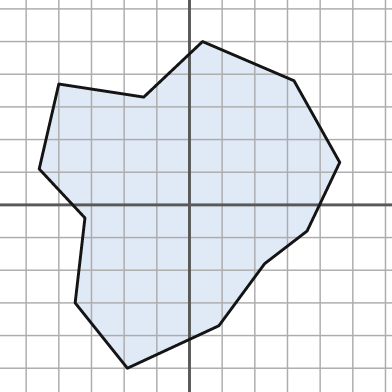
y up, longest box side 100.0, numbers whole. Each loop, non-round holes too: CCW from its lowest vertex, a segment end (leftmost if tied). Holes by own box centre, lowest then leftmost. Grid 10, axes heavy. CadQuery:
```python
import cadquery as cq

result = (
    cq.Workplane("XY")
    .moveTo(-19.0, -50.0)
    .lineTo(9.0, -37.0)
    .lineTo(23.0, -18.0)
    .lineTo(36.0, -8.0)
    .lineTo(46.0, 13.0)
    .lineTo(32.0, 38.0)
    .lineTo(4.0, 50.0)
    .lineTo(-14.0, 33.0)
    .lineTo(-40.0, 37.0)
    .lineTo(-46.0, 11.0)
    .lineTo(-32.0, -4.0)
    .lineTo(-35.0, -30.0)
    .close()
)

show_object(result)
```